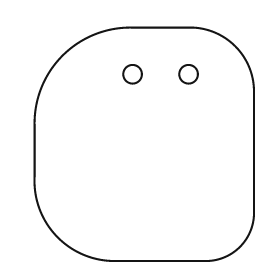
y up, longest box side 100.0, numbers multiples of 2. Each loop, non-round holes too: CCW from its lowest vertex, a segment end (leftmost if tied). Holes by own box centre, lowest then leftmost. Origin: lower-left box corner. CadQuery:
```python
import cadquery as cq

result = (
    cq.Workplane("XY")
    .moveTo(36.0, 0.0)
    .lineTo(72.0, 0.0)
    .threePointArc((88.0, 6.0), (94.0, 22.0))
    .lineTo(94.0, 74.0)
    .threePointArc((86.0, 92.0), (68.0, 100.0))
    .lineTo(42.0, 100.0)
    .threePointArc((12.0, 88.0), (0.0, 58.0))
    .lineTo(0.0, 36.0)
    .threePointArc((10.0, 10.0), (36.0, 0.0))
    .close()
    .moveTo(42.0, 80.0)
    .circle(4.0)
    .moveTo(66.0, 80.0)
    .circle(4.0)
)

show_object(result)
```